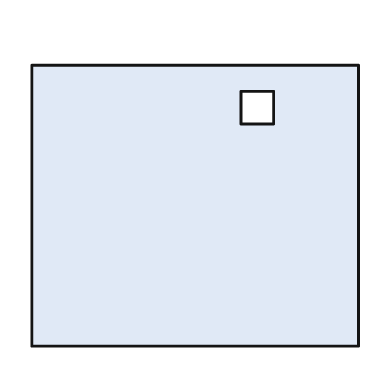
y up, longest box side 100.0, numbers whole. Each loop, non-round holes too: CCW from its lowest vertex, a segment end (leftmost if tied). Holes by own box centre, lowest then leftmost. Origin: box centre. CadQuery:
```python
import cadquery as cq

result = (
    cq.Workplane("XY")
    .moveTo(-50.0, -43.0)
    .lineTo(50.0, -43.0)
    .lineTo(50.0, 43.0)
    .lineTo(-50.0, 43.0)
    .close()
    .moveTo(14.0, 25.0)
    .lineTo(24.0, 25.0)
    .lineTo(24.0, 35.0)
    .lineTo(14.0, 35.0)
    .close()
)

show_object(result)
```